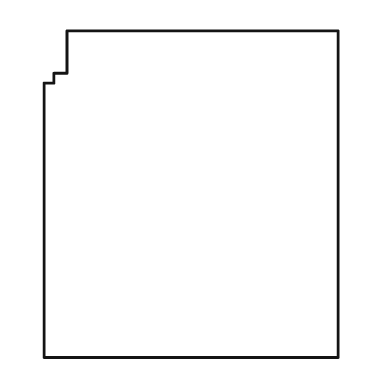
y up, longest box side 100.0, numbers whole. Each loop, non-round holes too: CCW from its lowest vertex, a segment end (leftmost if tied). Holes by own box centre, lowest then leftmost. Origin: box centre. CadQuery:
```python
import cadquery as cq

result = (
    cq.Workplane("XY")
    .moveTo(-45.0, -50.0)
    .lineTo(45.0, -50.0)
    .lineTo(45.0, 50.0)
    .lineTo(-38.0, 50.0)
    .lineTo(-38.0, 37.0)
    .lineTo(-42.0, 37.0)
    .lineTo(-42.0, 34.0)
    .lineTo(-45.0, 34.0)
    .close()
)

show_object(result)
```